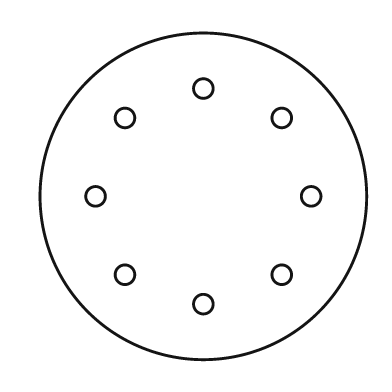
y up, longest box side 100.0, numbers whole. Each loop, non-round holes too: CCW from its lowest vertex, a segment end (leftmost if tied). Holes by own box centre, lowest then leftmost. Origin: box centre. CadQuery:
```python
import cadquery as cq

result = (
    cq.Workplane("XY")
    .moveTo(0.0, 0.0)
    .circle(50.0)
    .moveTo(0.0, -33.0)
    .circle(3.0)
    .moveTo(-24.0, -24.0)
    .circle(3.0)
    .moveTo(24.0, -24.0)
    .circle(3.0)
    .moveTo(-33.0, 0.0)
    .circle(3.0)
    .moveTo(33.0, 0.0)
    .circle(3.0)
    .moveTo(-24.0, 24.0)
    .circle(3.0)
    .moveTo(24.0, 24.0)
    .circle(3.0)
    .moveTo(0.0, 33.0)
    .circle(3.0)
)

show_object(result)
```